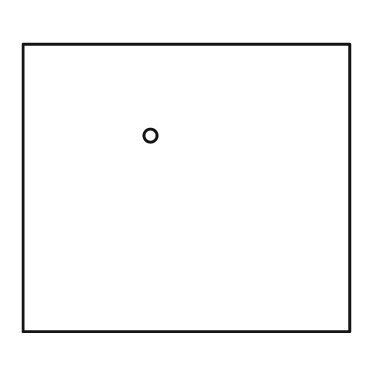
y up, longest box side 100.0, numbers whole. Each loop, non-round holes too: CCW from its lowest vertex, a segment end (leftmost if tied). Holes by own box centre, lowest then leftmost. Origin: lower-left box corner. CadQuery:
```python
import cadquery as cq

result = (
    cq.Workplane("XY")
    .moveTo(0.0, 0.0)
    .lineTo(100.0, 0.0)
    .lineTo(100.0, 88.0)
    .lineTo(0.0, 88.0)
    .close()
    .moveTo(39.0, 60.0)
    .circle(2.0)
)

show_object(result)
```